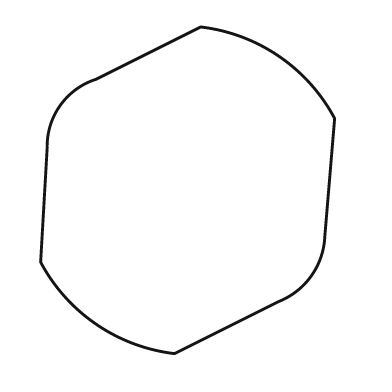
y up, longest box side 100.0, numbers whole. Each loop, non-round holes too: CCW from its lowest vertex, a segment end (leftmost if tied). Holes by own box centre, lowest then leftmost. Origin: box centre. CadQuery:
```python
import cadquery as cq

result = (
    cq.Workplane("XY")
    .moveTo(-4.0, -50.0)
    .lineTo(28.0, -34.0)
    .threePointArc((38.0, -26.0), (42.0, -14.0))
    .lineTo(45.0, 22.0)
    .threePointArc((28.0, 41.0), (4.0, 50.0))
    .lineTo(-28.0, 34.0)
    .threePointArc((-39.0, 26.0), (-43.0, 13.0))
    .lineTo(-45.0, -22.0)
    .threePointArc((-28.0, -41.0), (-4.0, -50.0))
    .close()
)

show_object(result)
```